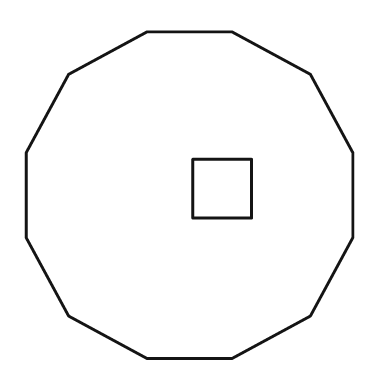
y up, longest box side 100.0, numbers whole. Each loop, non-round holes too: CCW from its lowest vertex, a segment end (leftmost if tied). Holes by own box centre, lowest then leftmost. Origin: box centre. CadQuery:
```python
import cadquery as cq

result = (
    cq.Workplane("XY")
    .moveTo(-13.0, -50.0)
    .lineTo(13.0, -50.0)
    .lineTo(37.0, -37.0)
    .lineTo(50.0, -13.0)
    .lineTo(50.0, 13.0)
    .lineTo(37.0, 37.0)
    .lineTo(13.0, 50.0)
    .lineTo(-13.0, 50.0)
    .lineTo(-37.0, 37.0)
    .lineTo(-50.0, 13.0)
    .lineTo(-50.0, -13.0)
    .lineTo(-37.0, -37.0)
    .close()
    .moveTo(1.0, -7.0)
    .lineTo(19.0, -7.0)
    .lineTo(19.0, 11.0)
    .lineTo(1.0, 11.0)
    .close()
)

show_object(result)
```